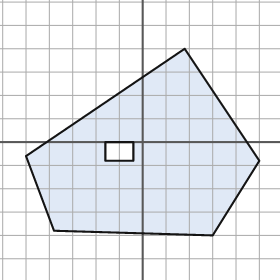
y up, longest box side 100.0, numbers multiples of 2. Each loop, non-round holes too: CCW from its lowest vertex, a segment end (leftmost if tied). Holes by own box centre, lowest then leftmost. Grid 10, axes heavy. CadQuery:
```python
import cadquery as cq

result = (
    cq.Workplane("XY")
    .moveTo(30.0, -40.0)
    .lineTo(50.0, -8.0)
    .lineTo(18.0, 40.0)
    .lineTo(-50.0, -6.0)
    .lineTo(-38.0, -38.0)
    .close()
    .moveTo(-16.0, -8.0)
    .lineTo(-4.0, -8.0)
    .lineTo(-4.0, 0.0)
    .lineTo(-16.0, 0.0)
    .close()
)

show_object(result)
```